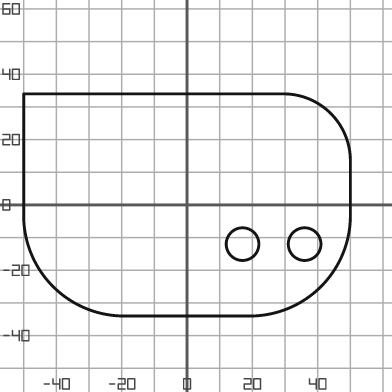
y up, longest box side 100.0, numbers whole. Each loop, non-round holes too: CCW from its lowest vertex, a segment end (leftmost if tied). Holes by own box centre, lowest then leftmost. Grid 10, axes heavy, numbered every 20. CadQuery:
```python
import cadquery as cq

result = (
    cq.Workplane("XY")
    .moveTo(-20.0, -34.0)
    .lineTo(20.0, -34.0)
    .threePointArc((41.0, -25.0), (50.0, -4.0))
    .lineTo(50.0, 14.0)
    .threePointArc((44.0, 28.0), (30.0, 34.0))
    .lineTo(-50.0, 34.0)
    .lineTo(-50.0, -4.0)
    .threePointArc((-41.0, -25.0), (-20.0, -34.0))
    .close()
    .moveTo(17.0, -12.0)
    .circle(5.0)
    .moveTo(36.0, -12.0)
    .circle(5.0)
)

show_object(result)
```